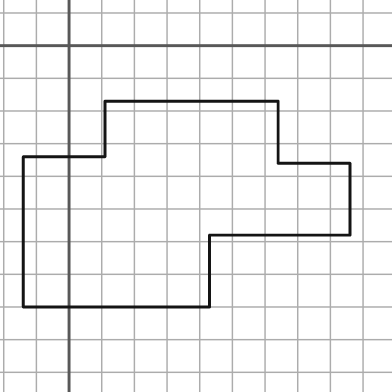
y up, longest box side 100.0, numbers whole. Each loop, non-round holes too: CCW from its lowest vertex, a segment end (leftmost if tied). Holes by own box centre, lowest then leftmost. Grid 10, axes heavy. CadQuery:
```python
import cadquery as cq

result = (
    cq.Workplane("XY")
    .moveTo(-14.0, -80.0)
    .lineTo(43.0, -80.0)
    .lineTo(43.0, -58.0)
    .lineTo(86.0, -58.0)
    .lineTo(86.0, -36.0)
    .lineTo(64.0, -36.0)
    .lineTo(64.0, -17.0)
    .lineTo(11.0, -17.0)
    .lineTo(11.0, -34.0)
    .lineTo(-14.0, -34.0)
    .close()
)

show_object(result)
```